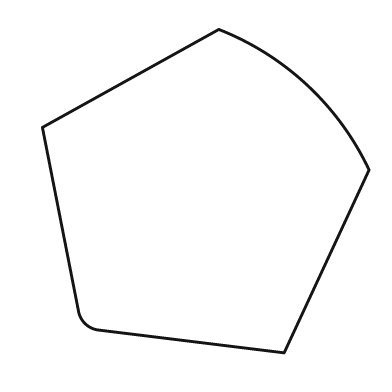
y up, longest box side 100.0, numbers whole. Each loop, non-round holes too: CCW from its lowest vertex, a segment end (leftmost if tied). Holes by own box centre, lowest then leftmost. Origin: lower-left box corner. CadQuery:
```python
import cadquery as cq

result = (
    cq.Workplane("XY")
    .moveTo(74.0, 0.0)
    .lineTo(100.0, 56.0)
    .threePointArc((81.0, 82.0), (54.0, 99.0))
    .lineTo(0.0, 69.0)
    .lineTo(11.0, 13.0)
    .threePointArc((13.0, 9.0), (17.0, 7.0))
    .close()
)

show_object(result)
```